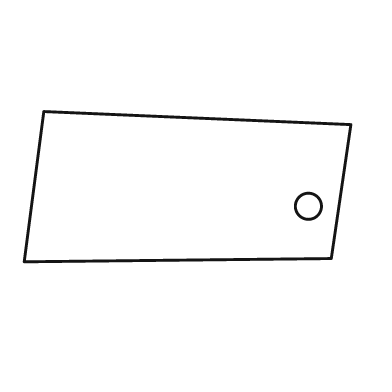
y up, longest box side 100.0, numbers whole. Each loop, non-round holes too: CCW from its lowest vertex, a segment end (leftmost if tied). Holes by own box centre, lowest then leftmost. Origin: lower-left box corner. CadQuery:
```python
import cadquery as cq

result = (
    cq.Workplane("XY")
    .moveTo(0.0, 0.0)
    .lineTo(94.0, 1.0)
    .lineTo(100.0, 42.0)
    .lineTo(6.0, 46.0)
    .close()
    .moveTo(87.0, 17.0)
    .circle(4.0)
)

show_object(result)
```